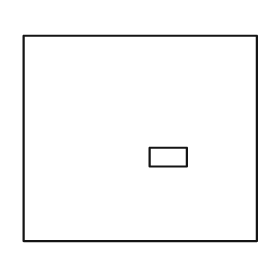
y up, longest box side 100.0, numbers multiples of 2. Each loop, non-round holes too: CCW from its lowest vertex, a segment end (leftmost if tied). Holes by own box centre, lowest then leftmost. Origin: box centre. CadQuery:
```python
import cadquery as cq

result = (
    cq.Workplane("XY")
    .moveTo(-50.0, -44.0)
    .lineTo(50.0, -44.0)
    .lineTo(50.0, 44.0)
    .lineTo(-50.0, 44.0)
    .close()
    .moveTo(4.0, -12.0)
    .lineTo(20.0, -12.0)
    .lineTo(20.0, -4.0)
    .lineTo(4.0, -4.0)
    .close()
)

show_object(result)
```